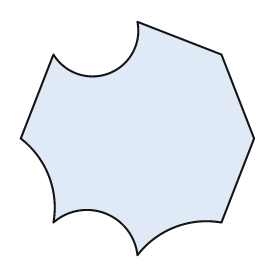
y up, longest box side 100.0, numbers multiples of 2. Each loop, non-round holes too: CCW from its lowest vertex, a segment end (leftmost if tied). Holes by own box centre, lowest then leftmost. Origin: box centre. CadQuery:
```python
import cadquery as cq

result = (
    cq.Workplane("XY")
    .moveTo(0.0, -50.0)
    .threePointArc((16.0, -38.0), (36.0, -36.0))
    .lineTo(50.0, 0.0)
    .lineTo(36.0, 36.0)
    .lineTo(0.0, 50.0)
    .threePointArc((-12.0, 28.0), (-36.0, 36.0))
    .lineTo(-50.0, 0.0)
    .threePointArc((-38.0, -16.0), (-36.0, -36.0))
    .threePointArc((-14.0, -32.0), (0.0, -50.0))
    .close()
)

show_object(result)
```